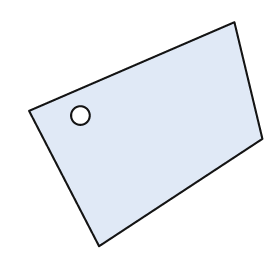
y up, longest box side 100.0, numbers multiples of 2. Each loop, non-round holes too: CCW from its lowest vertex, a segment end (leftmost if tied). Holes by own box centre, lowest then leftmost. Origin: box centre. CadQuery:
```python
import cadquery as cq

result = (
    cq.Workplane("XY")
    .moveTo(-20.0, -48.0)
    .lineTo(50.0, -2.0)
    .lineTo(38.0, 48.0)
    .lineTo(-50.0, 10.0)
    .close()
    .moveTo(-28.0, 8.0)
    .circle(4.0)
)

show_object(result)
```